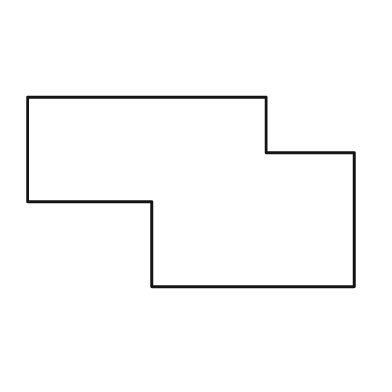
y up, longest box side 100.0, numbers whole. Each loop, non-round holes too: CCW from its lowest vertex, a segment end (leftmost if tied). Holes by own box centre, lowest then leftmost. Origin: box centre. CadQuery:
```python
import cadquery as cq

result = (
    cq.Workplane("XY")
    .moveTo(-12.0, -29.0)
    .lineTo(50.0, -29.0)
    .lineTo(50.0, 12.0)
    .lineTo(23.0, 12.0)
    .lineTo(23.0, 29.0)
    .lineTo(-50.0, 29.0)
    .lineTo(-50.0, -3.0)
    .lineTo(-12.0, -3.0)
    .close()
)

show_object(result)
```